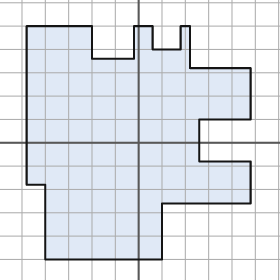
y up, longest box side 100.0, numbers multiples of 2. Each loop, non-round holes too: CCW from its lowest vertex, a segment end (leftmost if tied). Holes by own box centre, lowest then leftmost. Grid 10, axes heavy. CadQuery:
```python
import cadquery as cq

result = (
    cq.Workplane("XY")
    .moveTo(-40.0, -50.0)
    .lineTo(10.0, -50.0)
    .lineTo(10.0, -26.0)
    .lineTo(48.0, -26.0)
    .lineTo(48.0, -8.0)
    .lineTo(26.0, -8.0)
    .lineTo(26.0, 10.0)
    .lineTo(48.0, 10.0)
    .lineTo(48.0, 32.0)
    .lineTo(22.0, 32.0)
    .lineTo(22.0, 50.0)
    .lineTo(18.0, 50.0)
    .lineTo(18.0, 40.0)
    .lineTo(6.0, 40.0)
    .lineTo(6.0, 50.0)
    .lineTo(-2.0, 50.0)
    .lineTo(-2.0, 36.0)
    .lineTo(-20.0, 36.0)
    .lineTo(-20.0, 50.0)
    .lineTo(-48.0, 50.0)
    .lineTo(-48.0, -18.0)
    .lineTo(-40.0, -18.0)
    .close()
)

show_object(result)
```